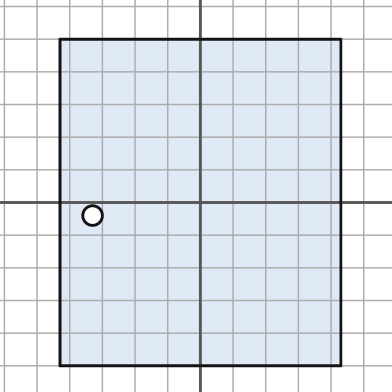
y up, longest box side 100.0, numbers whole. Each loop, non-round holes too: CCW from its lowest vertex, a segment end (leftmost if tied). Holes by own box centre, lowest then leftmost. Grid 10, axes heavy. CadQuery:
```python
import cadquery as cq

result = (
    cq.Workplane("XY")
    .moveTo(-43.0, -50.0)
    .lineTo(43.0, -50.0)
    .lineTo(43.0, 50.0)
    .lineTo(-43.0, 50.0)
    .close()
    .moveTo(-33.0, -4.0)
    .circle(3.0)
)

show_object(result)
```